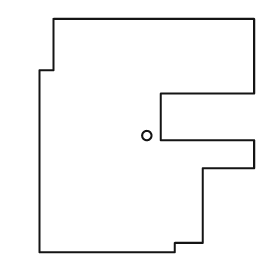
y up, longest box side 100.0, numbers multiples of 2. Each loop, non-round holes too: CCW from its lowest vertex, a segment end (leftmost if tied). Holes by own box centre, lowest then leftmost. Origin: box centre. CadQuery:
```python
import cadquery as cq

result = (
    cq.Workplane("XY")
    .moveTo(-46.0, -50.0)
    .lineTo(12.0, -50.0)
    .lineTo(12.0, -46.0)
    .lineTo(24.0, -46.0)
    .lineTo(24.0, -14.0)
    .lineTo(46.0, -14.0)
    .lineTo(46.0, -2.0)
    .lineTo(6.0, -2.0)
    .lineTo(6.0, 18.0)
    .lineTo(46.0, 18.0)
    .lineTo(46.0, 50.0)
    .lineTo(-40.0, 50.0)
    .lineTo(-40.0, 28.0)
    .lineTo(-46.0, 28.0)
    .close()
    .moveTo(0.0, 0.0)
    .circle(2.0)
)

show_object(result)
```